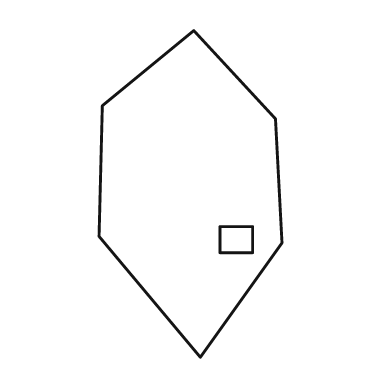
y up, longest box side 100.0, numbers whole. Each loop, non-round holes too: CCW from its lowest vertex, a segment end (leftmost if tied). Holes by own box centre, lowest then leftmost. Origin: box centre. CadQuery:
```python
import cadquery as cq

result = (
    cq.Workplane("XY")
    .moveTo(3.0, -50.0)
    .lineTo(28.0, -15.0)
    .lineTo(26.0, 23.0)
    .lineTo(1.0, 50.0)
    .lineTo(-27.0, 27.0)
    .lineTo(-28.0, -13.0)
    .close()
    .moveTo(9.0, -18.0)
    .lineTo(19.0, -18.0)
    .lineTo(19.0, -10.0)
    .lineTo(9.0, -10.0)
    .close()
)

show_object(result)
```